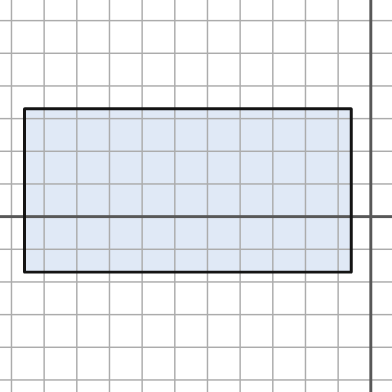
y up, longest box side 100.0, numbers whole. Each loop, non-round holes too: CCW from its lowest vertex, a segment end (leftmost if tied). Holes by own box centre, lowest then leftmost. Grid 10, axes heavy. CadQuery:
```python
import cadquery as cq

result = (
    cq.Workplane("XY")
    .moveTo(-106.0, -17.0)
    .lineTo(-6.0, -17.0)
    .lineTo(-6.0, 33.0)
    .lineTo(-106.0, 33.0)
    .close()
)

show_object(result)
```